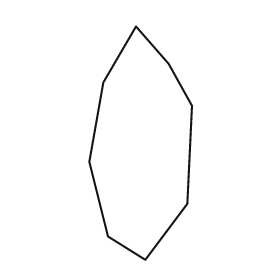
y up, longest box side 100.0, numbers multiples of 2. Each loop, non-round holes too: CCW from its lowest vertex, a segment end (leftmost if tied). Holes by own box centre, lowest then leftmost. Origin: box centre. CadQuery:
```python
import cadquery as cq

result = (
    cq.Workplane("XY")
    .moveTo(2.0, -50.0)
    .lineTo(20.0, -26.0)
    .lineTo(22.0, 16.0)
    .lineTo(12.0, 34.0)
    .lineTo(-2.0, 50.0)
    .lineTo(-16.0, 26.0)
    .lineTo(-22.0, -8.0)
    .lineTo(-14.0, -40.0)
    .close()
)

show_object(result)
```